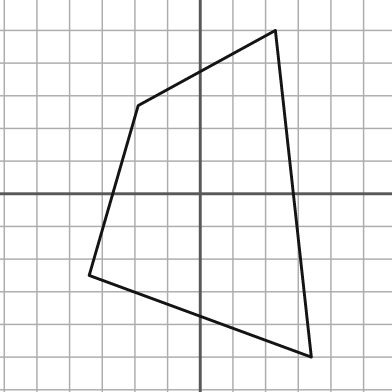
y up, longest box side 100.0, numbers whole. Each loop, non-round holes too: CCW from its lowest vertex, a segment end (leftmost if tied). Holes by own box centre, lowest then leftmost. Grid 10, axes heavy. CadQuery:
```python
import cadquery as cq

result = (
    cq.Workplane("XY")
    .moveTo(34.0, -50.0)
    .lineTo(23.0, 50.0)
    .lineTo(-19.0, 27.0)
    .lineTo(-34.0, -25.0)
    .close()
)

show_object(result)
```